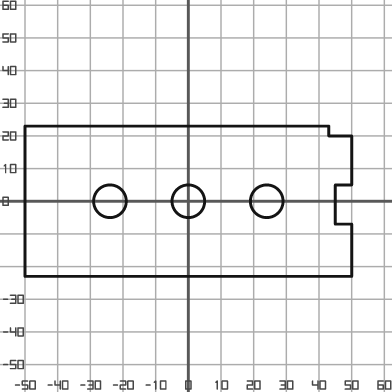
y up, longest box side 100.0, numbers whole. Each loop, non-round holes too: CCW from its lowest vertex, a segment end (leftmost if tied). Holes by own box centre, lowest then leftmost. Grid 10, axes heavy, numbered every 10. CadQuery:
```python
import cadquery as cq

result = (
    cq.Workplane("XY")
    .moveTo(-50.0, -23.0)
    .lineTo(50.0, -23.0)
    .lineTo(50.0, -7.0)
    .lineTo(45.0, -7.0)
    .lineTo(45.0, 5.0)
    .lineTo(50.0, 5.0)
    .lineTo(50.0, 20.0)
    .lineTo(43.0, 20.0)
    .lineTo(43.0, 23.0)
    .lineTo(-50.0, 23.0)
    .close()
    .moveTo(-24.0, 0.0)
    .circle(5.0)
    .moveTo(0.0, 0.0)
    .circle(5.0)
    .moveTo(24.0, 0.0)
    .circle(5.0)
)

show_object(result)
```